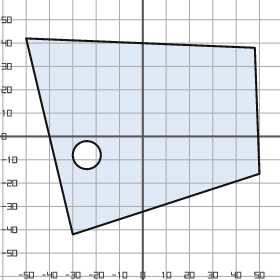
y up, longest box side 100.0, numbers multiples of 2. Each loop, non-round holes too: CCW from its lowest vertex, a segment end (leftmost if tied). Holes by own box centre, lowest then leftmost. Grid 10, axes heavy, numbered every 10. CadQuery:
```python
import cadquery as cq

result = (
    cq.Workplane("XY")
    .moveTo(-30.0, -42.0)
    .lineTo(50.0, -16.0)
    .lineTo(48.0, 38.0)
    .lineTo(-50.0, 42.0)
    .close()
    .moveTo(-24.0, -8.0)
    .circle(6.0)
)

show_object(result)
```